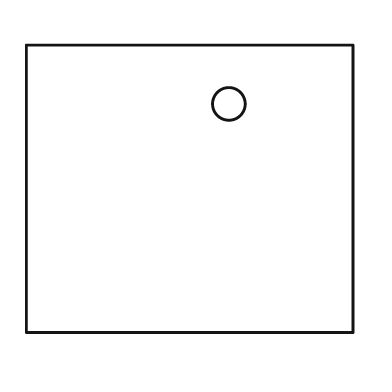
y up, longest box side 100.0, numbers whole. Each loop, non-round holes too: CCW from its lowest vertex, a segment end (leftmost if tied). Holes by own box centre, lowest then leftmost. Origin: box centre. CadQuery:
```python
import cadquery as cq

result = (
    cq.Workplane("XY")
    .moveTo(-50.0, -44.0)
    .lineTo(50.0, -44.0)
    .lineTo(50.0, 44.0)
    .lineTo(-50.0, 44.0)
    .close()
    .moveTo(12.0, 26.0)
    .circle(5.0)
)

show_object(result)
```